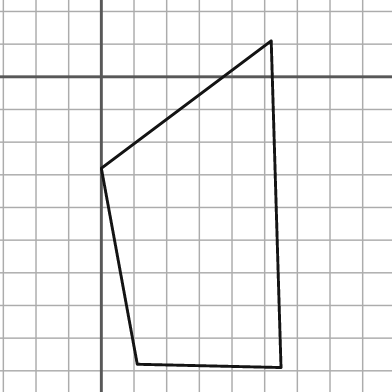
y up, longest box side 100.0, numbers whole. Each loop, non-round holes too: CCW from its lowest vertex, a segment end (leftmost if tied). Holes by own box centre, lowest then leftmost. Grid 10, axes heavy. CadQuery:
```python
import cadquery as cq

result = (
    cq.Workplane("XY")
    .moveTo(55.0, -89.0)
    .lineTo(52.0, 11.0)
    .lineTo(0.0, -28.0)
    .lineTo(11.0, -88.0)
    .close()
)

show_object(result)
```